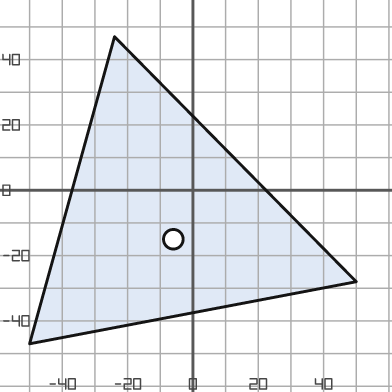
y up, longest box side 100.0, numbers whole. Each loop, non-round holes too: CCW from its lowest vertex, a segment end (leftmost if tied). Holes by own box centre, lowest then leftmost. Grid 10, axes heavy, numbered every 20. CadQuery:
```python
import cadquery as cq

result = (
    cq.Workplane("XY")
    .moveTo(-50.0, -47.0)
    .lineTo(50.0, -28.0)
    .lineTo(-24.0, 47.0)
    .close()
    .moveTo(-6.0, -15.0)
    .circle(3.0)
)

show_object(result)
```